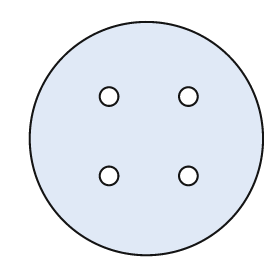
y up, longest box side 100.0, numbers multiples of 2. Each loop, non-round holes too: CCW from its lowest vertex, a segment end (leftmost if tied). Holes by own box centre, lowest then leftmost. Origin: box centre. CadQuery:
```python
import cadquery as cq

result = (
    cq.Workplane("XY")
    .moveTo(0.0, 0.0)
    .circle(50.0)
    .moveTo(-16.0, -16.0)
    .circle(4.0)
    .moveTo(18.0, -16.0)
    .circle(4.0)
    .moveTo(-16.0, 18.0)
    .circle(4.0)
    .moveTo(18.0, 18.0)
    .circle(4.0)
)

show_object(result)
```